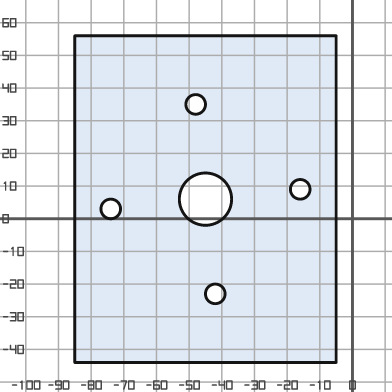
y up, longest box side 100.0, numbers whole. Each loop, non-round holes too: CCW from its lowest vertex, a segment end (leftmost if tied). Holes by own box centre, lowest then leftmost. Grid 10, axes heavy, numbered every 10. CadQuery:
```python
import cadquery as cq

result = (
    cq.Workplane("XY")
    .moveTo(-85.0, -44.0)
    .lineTo(-5.0, -44.0)
    .lineTo(-5.0, 56.0)
    .lineTo(-85.0, 56.0)
    .close()
    .moveTo(-42.0, -23.0)
    .circle(3.0)
    .moveTo(-74.0, 3.0)
    .circle(3.0)
    .moveTo(-45.0, 6.0)
    .circle(8.0)
    .moveTo(-16.0, 9.0)
    .circle(3.0)
    .moveTo(-48.0, 35.0)
    .circle(3.0)
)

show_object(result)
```